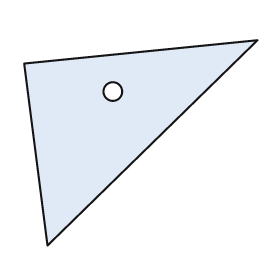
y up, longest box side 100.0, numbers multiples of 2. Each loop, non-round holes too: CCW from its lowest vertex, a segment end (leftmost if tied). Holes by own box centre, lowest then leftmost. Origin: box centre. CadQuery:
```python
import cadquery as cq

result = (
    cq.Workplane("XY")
    .moveTo(-40.0, -44.0)
    .lineTo(50.0, 44.0)
    .lineTo(-50.0, 34.0)
    .close()
    .moveTo(-12.0, 22.0)
    .circle(4.0)
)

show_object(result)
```